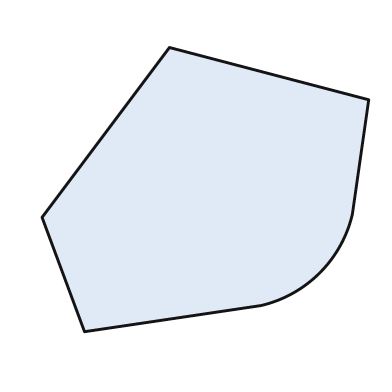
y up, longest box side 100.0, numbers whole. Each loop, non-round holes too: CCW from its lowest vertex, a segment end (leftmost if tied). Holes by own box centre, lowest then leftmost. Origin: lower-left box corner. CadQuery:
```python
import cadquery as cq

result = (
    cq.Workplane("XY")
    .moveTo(13.0, 0.0)
    .lineTo(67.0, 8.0)
    .threePointArc((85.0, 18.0), (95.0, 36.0))
    .lineTo(100.0, 71.0)
    .lineTo(39.0, 87.0)
    .lineTo(0.0, 35.0)
    .close()
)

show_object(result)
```